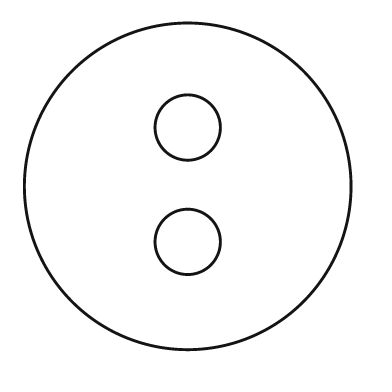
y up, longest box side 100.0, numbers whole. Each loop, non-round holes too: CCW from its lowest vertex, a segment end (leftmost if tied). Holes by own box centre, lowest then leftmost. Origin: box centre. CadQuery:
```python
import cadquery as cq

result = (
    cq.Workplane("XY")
    .moveTo(0.0, 0.0)
    .circle(50.0)
    .moveTo(0.0, -17.0)
    .circle(10.0)
    .moveTo(0.0, 18.0)
    .circle(10.0)
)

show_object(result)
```